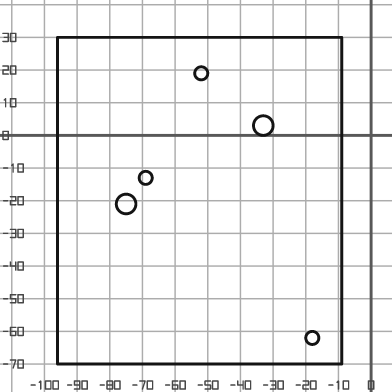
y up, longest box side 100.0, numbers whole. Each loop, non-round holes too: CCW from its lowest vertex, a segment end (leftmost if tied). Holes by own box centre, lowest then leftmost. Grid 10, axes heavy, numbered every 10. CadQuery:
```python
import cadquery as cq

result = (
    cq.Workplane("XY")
    .moveTo(-96.0, -70.0)
    .lineTo(-9.0, -70.0)
    .lineTo(-9.0, 30.0)
    .lineTo(-96.0, 30.0)
    .close()
    .moveTo(-18.0, -62.0)
    .circle(2.0)
    .moveTo(-75.0, -21.0)
    .circle(3.0)
    .moveTo(-69.0, -13.0)
    .circle(2.0)
    .moveTo(-33.0, 3.0)
    .circle(3.0)
    .moveTo(-52.0, 19.0)
    .circle(2.0)
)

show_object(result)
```